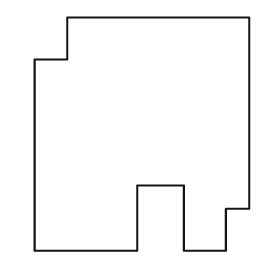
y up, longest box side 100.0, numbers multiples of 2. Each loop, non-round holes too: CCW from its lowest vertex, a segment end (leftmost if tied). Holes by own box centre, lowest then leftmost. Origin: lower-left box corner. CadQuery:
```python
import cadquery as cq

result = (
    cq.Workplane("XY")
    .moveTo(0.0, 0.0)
    .lineTo(44.0, 0.0)
    .lineTo(44.0, 28.0)
    .lineTo(64.0, 28.0)
    .lineTo(64.0, 0.0)
    .lineTo(82.0, 0.0)
    .lineTo(82.0, 18.0)
    .lineTo(92.0, 18.0)
    .lineTo(92.0, 100.0)
    .lineTo(14.0, 100.0)
    .lineTo(14.0, 82.0)
    .lineTo(0.0, 82.0)
    .close()
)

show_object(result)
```